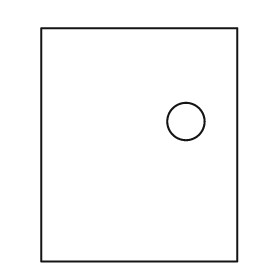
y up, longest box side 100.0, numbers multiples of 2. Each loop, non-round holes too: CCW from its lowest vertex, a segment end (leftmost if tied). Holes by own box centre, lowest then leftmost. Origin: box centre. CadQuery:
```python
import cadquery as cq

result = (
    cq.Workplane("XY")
    .moveTo(-42.0, -50.0)
    .lineTo(42.0, -50.0)
    .lineTo(42.0, 50.0)
    .lineTo(-42.0, 50.0)
    .close()
    .moveTo(20.0, 10.0)
    .circle(8.0)
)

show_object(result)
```